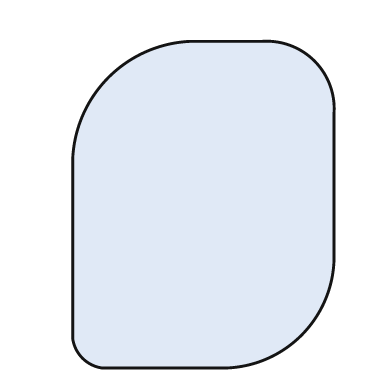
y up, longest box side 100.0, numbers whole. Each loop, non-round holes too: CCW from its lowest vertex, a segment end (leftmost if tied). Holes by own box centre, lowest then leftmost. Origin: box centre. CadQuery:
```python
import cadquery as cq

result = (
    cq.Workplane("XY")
    .moveTo(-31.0, -50.0)
    .lineTo(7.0, -50.0)
    .threePointArc((30.0, -40.0), (40.0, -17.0))
    .lineTo(40.0, 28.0)
    .threePointArc((34.0, 44.0), (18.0, 50.0))
    .lineTo(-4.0, 50.0)
    .threePointArc((-29.0, 39.0), (-40.0, 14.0))
    .lineTo(-40.0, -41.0)
    .threePointArc((-37.0, -47.0), (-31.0, -50.0))
    .close()
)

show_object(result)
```